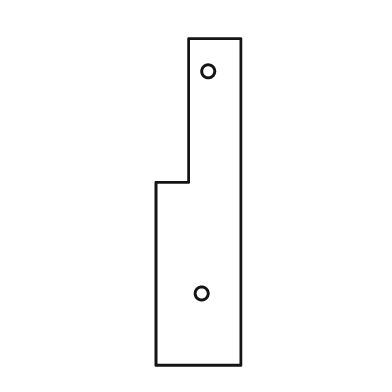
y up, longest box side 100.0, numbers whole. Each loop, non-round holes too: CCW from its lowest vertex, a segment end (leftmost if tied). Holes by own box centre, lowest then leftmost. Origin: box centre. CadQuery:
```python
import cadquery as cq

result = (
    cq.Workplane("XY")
    .moveTo(-13.0, -50.0)
    .lineTo(13.0, -50.0)
    .lineTo(13.0, 50.0)
    .lineTo(-3.0, 50.0)
    .lineTo(-3.0, 6.0)
    .lineTo(-13.0, 6.0)
    .close()
    .moveTo(1.0, -28.0)
    .circle(2.0)
    .moveTo(3.0, 40.0)
    .circle(2.0)
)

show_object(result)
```